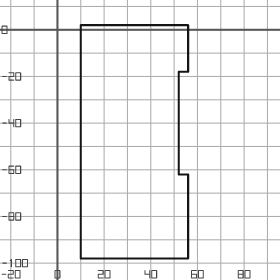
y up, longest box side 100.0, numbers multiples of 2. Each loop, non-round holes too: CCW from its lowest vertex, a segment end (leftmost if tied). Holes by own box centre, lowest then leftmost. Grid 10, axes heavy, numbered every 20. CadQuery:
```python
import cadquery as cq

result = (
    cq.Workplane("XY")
    .moveTo(10.0, -98.0)
    .lineTo(56.0, -98.0)
    .lineTo(56.0, -62.0)
    .lineTo(52.0, -62.0)
    .lineTo(52.0, -18.0)
    .lineTo(56.0, -18.0)
    .lineTo(56.0, 2.0)
    .lineTo(10.0, 2.0)
    .close()
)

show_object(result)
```